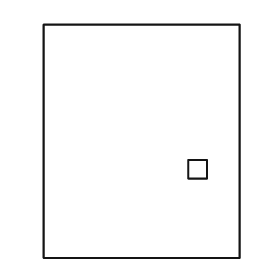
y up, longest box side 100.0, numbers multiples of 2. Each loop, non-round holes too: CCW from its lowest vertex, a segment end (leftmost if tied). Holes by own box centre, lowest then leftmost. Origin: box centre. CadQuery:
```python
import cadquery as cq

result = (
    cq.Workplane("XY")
    .moveTo(-42.0, -50.0)
    .lineTo(42.0, -50.0)
    .lineTo(42.0, 50.0)
    .lineTo(-42.0, 50.0)
    .close()
    .moveTo(20.0, -16.0)
    .lineTo(28.0, -16.0)
    .lineTo(28.0, -8.0)
    .lineTo(20.0, -8.0)
    .close()
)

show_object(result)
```